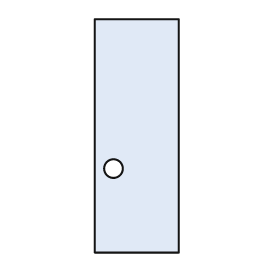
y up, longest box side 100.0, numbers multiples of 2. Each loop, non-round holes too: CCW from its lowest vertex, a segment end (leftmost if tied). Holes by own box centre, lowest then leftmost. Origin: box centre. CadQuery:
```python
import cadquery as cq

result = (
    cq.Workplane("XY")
    .moveTo(-18.0, -50.0)
    .lineTo(18.0, -50.0)
    .lineTo(18.0, 50.0)
    .lineTo(-18.0, 50.0)
    .close()
    .moveTo(-10.0, -14.0)
    .circle(4.0)
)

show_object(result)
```